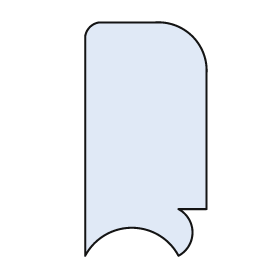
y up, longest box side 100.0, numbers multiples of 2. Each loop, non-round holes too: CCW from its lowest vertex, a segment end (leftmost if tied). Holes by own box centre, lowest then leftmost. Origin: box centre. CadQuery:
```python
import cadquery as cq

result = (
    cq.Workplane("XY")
    .moveTo(-26.0, -50.0)
    .threePointArc((-6.0, -38.0), (14.0, -50.0))
    .threePointArc((20.0, -40.0), (14.0, -30.0))
    .lineTo(26.0, -30.0)
    .lineTo(26.0, 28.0)
    .threePointArc((20.0, 44.0), (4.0, 50.0))
    .lineTo(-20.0, 50.0)
    .threePointArc((-24.0, 48.0), (-26.0, 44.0))
    .close()
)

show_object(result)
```